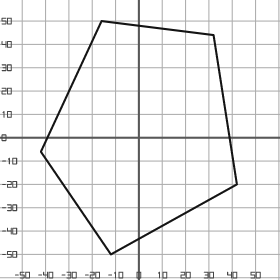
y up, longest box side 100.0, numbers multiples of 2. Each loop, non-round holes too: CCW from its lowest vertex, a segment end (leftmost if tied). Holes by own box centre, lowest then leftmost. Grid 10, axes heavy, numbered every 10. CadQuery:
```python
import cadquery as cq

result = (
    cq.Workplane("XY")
    .moveTo(-12.0, -50.0)
    .lineTo(42.0, -20.0)
    .lineTo(32.0, 44.0)
    .lineTo(-16.0, 50.0)
    .lineTo(-42.0, -6.0)
    .close()
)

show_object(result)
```